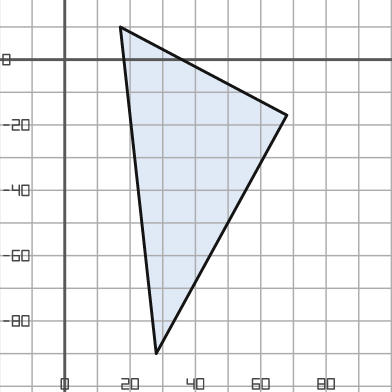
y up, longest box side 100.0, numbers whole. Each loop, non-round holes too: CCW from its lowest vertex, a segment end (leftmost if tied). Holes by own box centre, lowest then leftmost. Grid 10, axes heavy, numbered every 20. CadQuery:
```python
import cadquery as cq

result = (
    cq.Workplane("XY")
    .moveTo(28.0, -90.0)
    .lineTo(68.0, -17.0)
    .lineTo(17.0, 10.0)
    .close()
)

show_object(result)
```